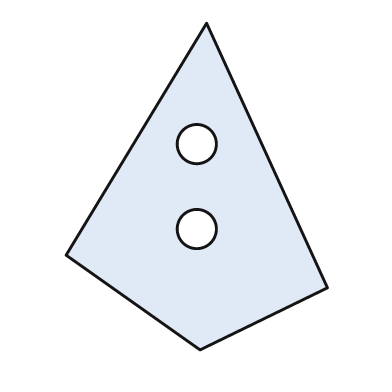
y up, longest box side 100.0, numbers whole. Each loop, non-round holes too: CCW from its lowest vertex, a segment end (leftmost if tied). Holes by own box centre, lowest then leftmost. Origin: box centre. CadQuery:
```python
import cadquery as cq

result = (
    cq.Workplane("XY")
    .moveTo(1.0, -50.0)
    .lineTo(40.0, -31.0)
    .lineTo(3.0, 50.0)
    .lineTo(-40.0, -21.0)
    .close()
    .moveTo(0.0, -13.0)
    .circle(6.0)
    .moveTo(0.0, 13.0)
    .circle(6.0)
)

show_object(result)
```